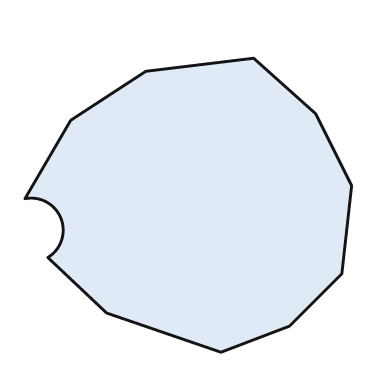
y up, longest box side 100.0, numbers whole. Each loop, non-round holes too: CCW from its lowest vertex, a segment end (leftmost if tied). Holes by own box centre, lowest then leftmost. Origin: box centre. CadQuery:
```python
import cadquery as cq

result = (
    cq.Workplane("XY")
    .moveTo(10.0, -45.0)
    .lineTo(31.0, -37.0)
    .lineTo(47.0, -21.0)
    .lineTo(50.0, 6.0)
    .lineTo(39.0, 28.0)
    .lineTo(20.0, 45.0)
    .lineTo(-13.0, 41.0)
    .lineTo(-36.0, 26.0)
    .lineTo(-50.0, 2.0)
    .threePointArc((-39.0, -4.0), (-43.0, -16.0))
    .lineTo(-25.0, -33.0)
    .close()
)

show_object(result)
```